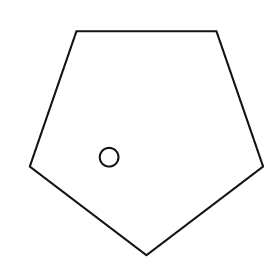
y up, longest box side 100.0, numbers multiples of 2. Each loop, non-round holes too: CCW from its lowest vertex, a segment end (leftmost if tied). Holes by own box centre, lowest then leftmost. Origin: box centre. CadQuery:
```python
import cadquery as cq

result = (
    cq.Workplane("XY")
    .moveTo(0.0, -48.0)
    .lineTo(50.0, -10.0)
    .lineTo(30.0, 48.0)
    .lineTo(-30.0, 48.0)
    .lineTo(-50.0, -10.0)
    .close()
    .moveTo(-16.0, -6.0)
    .circle(4.0)
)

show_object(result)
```